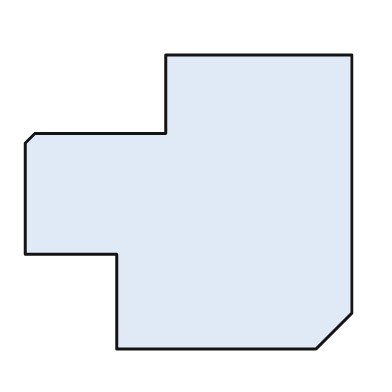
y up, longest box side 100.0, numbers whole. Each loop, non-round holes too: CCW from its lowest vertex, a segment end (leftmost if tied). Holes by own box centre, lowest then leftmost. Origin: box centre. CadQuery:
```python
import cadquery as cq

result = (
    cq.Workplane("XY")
    .moveTo(-22.0, -45.0)
    .lineTo(39.0, -45.0)
    .lineTo(50.0, -34.0)
    .lineTo(50.0, 45.0)
    .lineTo(-7.0, 45.0)
    .lineTo(-7.0, 21.0)
    .lineTo(-47.0, 21.0)
    .lineTo(-50.0, 18.0)
    .lineTo(-50.0, -16.0)
    .lineTo(-22.0, -16.0)
    .close()
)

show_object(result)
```